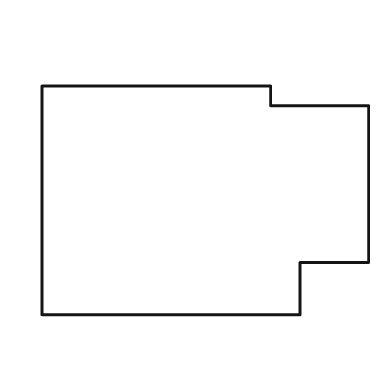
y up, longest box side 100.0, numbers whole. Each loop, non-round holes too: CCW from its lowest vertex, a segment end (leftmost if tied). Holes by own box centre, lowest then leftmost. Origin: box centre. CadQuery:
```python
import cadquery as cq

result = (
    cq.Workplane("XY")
    .moveTo(-50.0, -35.0)
    .lineTo(29.0, -35.0)
    .lineTo(29.0, -19.0)
    .lineTo(50.0, -19.0)
    .lineTo(50.0, 29.0)
    .lineTo(20.0, 29.0)
    .lineTo(20.0, 35.0)
    .lineTo(-50.0, 35.0)
    .close()
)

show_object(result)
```